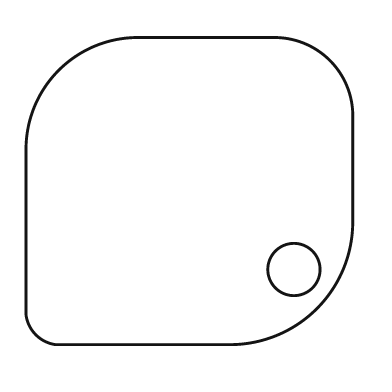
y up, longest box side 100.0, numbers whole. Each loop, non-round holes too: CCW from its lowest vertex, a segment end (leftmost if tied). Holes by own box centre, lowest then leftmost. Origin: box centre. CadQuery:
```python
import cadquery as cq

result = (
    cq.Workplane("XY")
    .moveTo(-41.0, -47.0)
    .lineTo(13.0, -47.0)
    .threePointArc((39.0, -36.0), (50.0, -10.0))
    .lineTo(50.0, 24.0)
    .threePointArc((43.0, 40.0), (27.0, 47.0))
    .lineTo(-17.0, 47.0)
    .threePointArc((-40.0, 37.0), (-50.0, 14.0))
    .lineTo(-50.0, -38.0)
    .threePointArc((-47.0, -44.0), (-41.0, -47.0))
    .close()
    .moveTo(32.0, -24.0)
    .circle(8.0)
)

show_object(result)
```